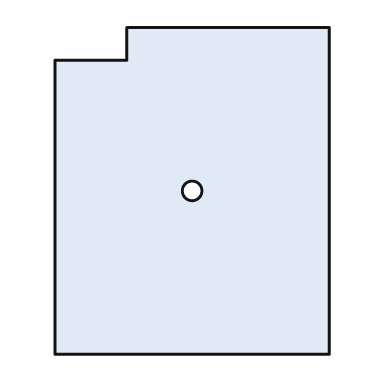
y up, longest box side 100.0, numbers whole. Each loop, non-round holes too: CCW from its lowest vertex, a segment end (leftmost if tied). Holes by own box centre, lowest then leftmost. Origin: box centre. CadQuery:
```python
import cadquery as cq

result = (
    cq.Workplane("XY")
    .moveTo(-42.0, -50.0)
    .lineTo(42.0, -50.0)
    .lineTo(42.0, 50.0)
    .lineTo(-20.0, 50.0)
    .lineTo(-20.0, 40.0)
    .lineTo(-42.0, 40.0)
    .close()
    .moveTo(0.0, 0.0)
    .circle(3.0)
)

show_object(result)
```